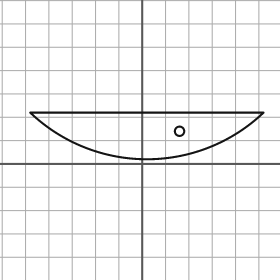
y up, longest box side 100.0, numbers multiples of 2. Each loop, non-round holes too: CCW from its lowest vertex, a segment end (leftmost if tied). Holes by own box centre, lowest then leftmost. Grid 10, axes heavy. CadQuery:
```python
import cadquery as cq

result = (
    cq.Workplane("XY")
    .moveTo(-48.0, 22.0)
    .threePointArc((2.0, 2.0), (52.0, 22.0))
    .close()
    .moveTo(16.0, 14.0)
    .circle(2.0)
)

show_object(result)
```